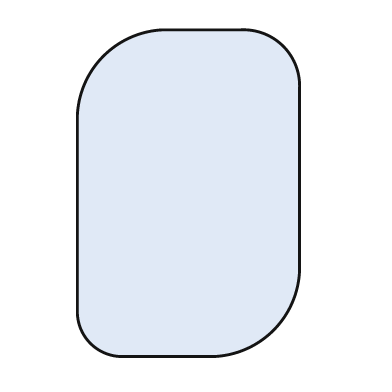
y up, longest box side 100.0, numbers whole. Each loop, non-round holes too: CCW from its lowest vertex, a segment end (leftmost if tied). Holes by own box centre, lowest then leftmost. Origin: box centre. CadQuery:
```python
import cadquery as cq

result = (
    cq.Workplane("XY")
    .moveTo(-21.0, -50.0)
    .lineTo(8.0, -50.0)
    .threePointArc((26.0, -42.0), (34.0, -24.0))
    .lineTo(34.0, 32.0)
    .threePointArc((29.0, 45.0), (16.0, 50.0))
    .lineTo(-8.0, 50.0)
    .threePointArc((-26.0, 42.0), (-34.0, 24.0))
    .lineTo(-34.0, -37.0)
    .threePointArc((-30.0, -46.0), (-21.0, -50.0))
    .close()
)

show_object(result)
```